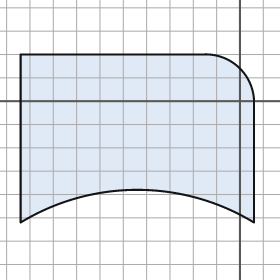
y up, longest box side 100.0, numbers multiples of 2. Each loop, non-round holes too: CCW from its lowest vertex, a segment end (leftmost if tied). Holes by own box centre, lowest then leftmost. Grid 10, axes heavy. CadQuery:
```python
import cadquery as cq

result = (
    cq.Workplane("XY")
    .moveTo(-94.0, -52.0)
    .threePointArc((-44.0, -38.0), (6.0, -52.0))
    .lineTo(6.0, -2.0)
    .threePointArc((0.0, 14.0), (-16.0, 20.0))
    .lineTo(-94.0, 20.0)
    .close()
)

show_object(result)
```